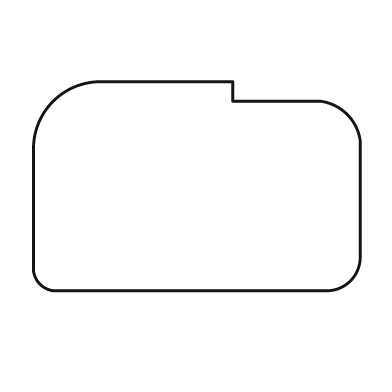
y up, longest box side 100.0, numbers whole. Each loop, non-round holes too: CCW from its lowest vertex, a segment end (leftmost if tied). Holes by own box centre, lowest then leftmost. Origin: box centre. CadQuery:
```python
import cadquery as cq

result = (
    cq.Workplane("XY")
    .moveTo(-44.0, -32.0)
    .lineTo(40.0, -32.0)
    .threePointArc((47.0, -29.0), (50.0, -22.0))
    .lineTo(50.0, 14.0)
    .threePointArc((46.0, 22.0), (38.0, 26.0))
    .lineTo(11.0, 26.0)
    .lineTo(11.0, 32.0)
    .lineTo(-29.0, 32.0)
    .threePointArc((-44.0, 26.0), (-50.0, 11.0))
    .lineTo(-50.0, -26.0)
    .threePointArc((-48.0, -30.0), (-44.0, -32.0))
    .close()
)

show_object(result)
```